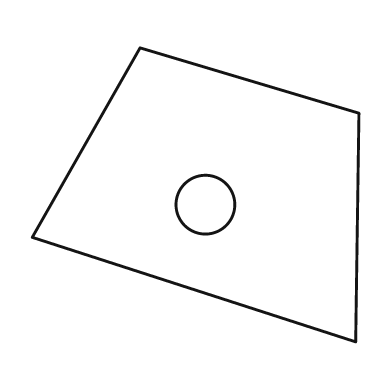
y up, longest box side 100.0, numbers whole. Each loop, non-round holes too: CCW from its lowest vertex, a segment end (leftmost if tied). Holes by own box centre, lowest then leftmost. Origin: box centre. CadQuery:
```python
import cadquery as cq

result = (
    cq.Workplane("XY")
    .moveTo(49.0, -45.0)
    .lineTo(50.0, 25.0)
    .lineTo(-17.0, 45.0)
    .lineTo(-50.0, -13.0)
    .close()
    .moveTo(3.0, -3.0)
    .circle(9.0)
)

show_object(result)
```